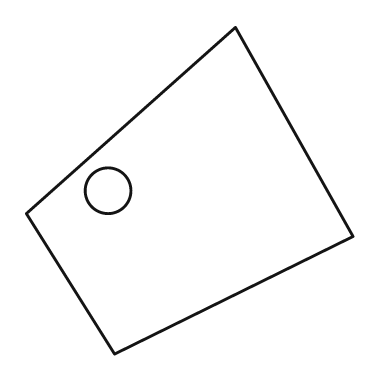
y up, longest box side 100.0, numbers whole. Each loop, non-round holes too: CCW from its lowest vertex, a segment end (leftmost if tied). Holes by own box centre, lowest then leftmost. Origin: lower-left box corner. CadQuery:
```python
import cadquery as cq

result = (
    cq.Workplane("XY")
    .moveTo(27.0, 0.0)
    .lineTo(100.0, 36.0)
    .lineTo(64.0, 100.0)
    .lineTo(0.0, 43.0)
    .close()
    .moveTo(25.0, 50.0)
    .circle(7.0)
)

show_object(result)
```